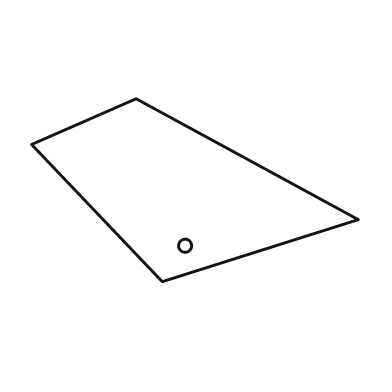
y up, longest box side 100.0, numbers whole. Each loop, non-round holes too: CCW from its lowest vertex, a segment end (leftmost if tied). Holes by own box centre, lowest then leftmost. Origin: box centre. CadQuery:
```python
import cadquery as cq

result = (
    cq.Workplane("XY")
    .moveTo(-10.0, -28.0)
    .lineTo(50.0, -9.0)
    .lineTo(-18.0, 28.0)
    .lineTo(-50.0, 14.0)
    .close()
    .moveTo(-3.0, -17.0)
    .circle(2.0)
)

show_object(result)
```